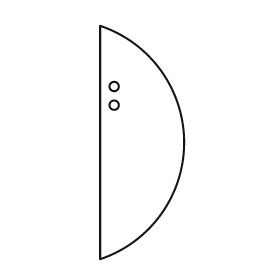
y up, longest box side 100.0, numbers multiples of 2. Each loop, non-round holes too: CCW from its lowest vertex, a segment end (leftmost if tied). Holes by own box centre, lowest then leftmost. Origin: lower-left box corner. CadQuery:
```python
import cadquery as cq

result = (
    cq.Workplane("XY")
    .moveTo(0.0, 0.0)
    .threePointArc((36.0, 50.0), (0.0, 100.0))
    .close()
    .moveTo(6.0, 66.0)
    .circle(2.0)
    .moveTo(6.0, 74.0)
    .circle(2.0)
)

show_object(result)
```